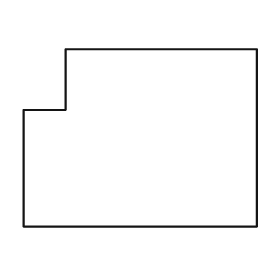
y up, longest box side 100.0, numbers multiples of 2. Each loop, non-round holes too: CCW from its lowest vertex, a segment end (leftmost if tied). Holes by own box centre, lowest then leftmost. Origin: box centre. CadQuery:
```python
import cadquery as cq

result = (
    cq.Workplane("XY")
    .moveTo(-50.0, -38.0)
    .lineTo(50.0, -38.0)
    .lineTo(50.0, 38.0)
    .lineTo(-32.0, 38.0)
    .lineTo(-32.0, 12.0)
    .lineTo(-50.0, 12.0)
    .close()
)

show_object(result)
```